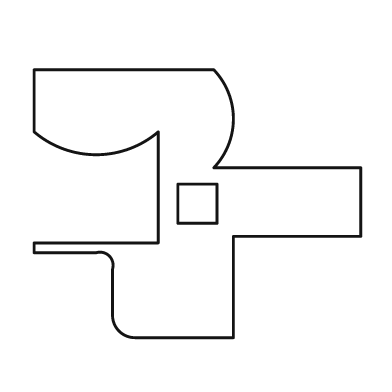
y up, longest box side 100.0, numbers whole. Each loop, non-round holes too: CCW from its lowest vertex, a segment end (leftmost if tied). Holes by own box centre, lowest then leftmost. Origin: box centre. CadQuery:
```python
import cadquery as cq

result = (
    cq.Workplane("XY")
    .moveTo(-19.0, -41.0)
    .lineTo(11.0, -41.0)
    .lineTo(11.0, -10.0)
    .lineTo(50.0, -10.0)
    .lineTo(50.0, 11.0)
    .lineTo(5.0, 11.0)
    .threePointArc((11.0, 26.0), (5.0, 41.0))
    .lineTo(-50.0, 41.0)
    .lineTo(-50.0, 22.0)
    .threePointArc((-31.0, 15.0), (-12.0, 22.0))
    .lineTo(-12.0, -12.0)
    .lineTo(-50.0, -12.0)
    .lineTo(-50.0, -15.0)
    .lineTo(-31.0, -15.0)
    .threePointArc((-27.0, -16.0), (-26.0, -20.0))
    .lineTo(-26.0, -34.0)
    .threePointArc((-24.0, -39.0), (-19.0, -41.0))
    .close()
    .moveTo(-6.0, -6.0)
    .lineTo(6.0, -6.0)
    .lineTo(6.0, 6.0)
    .lineTo(-6.0, 6.0)
    .close()
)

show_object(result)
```